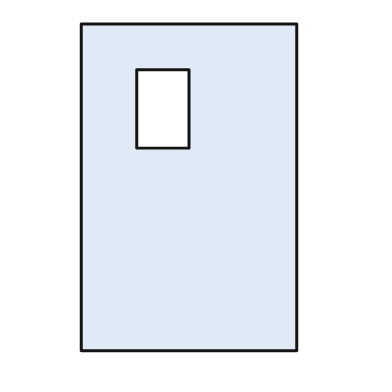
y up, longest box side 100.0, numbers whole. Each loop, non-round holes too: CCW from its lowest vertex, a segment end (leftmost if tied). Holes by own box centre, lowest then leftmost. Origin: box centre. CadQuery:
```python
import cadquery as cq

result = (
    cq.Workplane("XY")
    .moveTo(-33.0, -50.0)
    .lineTo(33.0, -50.0)
    .lineTo(33.0, 50.0)
    .lineTo(-33.0, 50.0)
    .close()
    .moveTo(-16.0, 12.0)
    .lineTo(0.0, 12.0)
    .lineTo(0.0, 36.0)
    .lineTo(-16.0, 36.0)
    .close()
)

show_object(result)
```